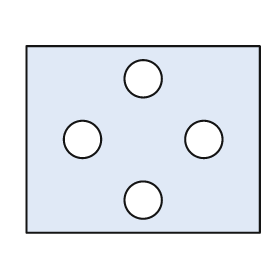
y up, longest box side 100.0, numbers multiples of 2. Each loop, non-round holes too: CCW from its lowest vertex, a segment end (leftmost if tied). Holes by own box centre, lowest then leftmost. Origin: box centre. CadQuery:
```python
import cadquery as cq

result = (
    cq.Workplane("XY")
    .moveTo(-50.0, -40.0)
    .lineTo(50.0, -40.0)
    .lineTo(50.0, 40.0)
    .lineTo(-50.0, 40.0)
    .close()
    .moveTo(0.0, -26.0)
    .circle(8.0)
    .moveTo(-26.0, 0.0)
    .circle(8.0)
    .moveTo(26.0, 0.0)
    .circle(8.0)
    .moveTo(0.0, 26.0)
    .circle(8.0)
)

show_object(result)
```